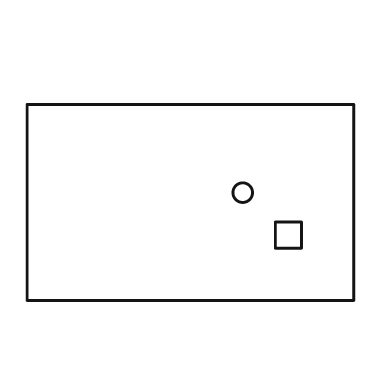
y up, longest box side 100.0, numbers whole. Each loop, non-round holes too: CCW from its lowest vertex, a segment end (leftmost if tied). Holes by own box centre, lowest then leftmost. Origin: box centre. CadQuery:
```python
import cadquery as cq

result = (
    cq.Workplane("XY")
    .moveTo(-50.0, -30.0)
    .lineTo(50.0, -30.0)
    .lineTo(50.0, 30.0)
    .lineTo(-50.0, 30.0)
    .close()
    .moveTo(26.0, -14.0)
    .lineTo(34.0, -14.0)
    .lineTo(34.0, -6.0)
    .lineTo(26.0, -6.0)
    .close()
    .moveTo(16.0, 3.0)
    .circle(3.0)
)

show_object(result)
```